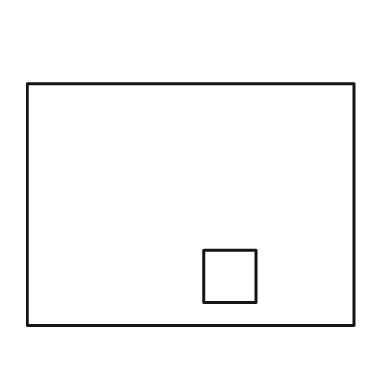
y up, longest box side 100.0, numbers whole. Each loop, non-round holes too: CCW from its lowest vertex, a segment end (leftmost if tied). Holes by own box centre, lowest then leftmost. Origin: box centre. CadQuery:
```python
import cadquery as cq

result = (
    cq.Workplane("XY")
    .moveTo(-50.0, -37.0)
    .lineTo(50.0, -37.0)
    .lineTo(50.0, 37.0)
    .lineTo(-50.0, 37.0)
    .close()
    .moveTo(4.0, -30.0)
    .lineTo(20.0, -30.0)
    .lineTo(20.0, -14.0)
    .lineTo(4.0, -14.0)
    .close()
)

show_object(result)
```